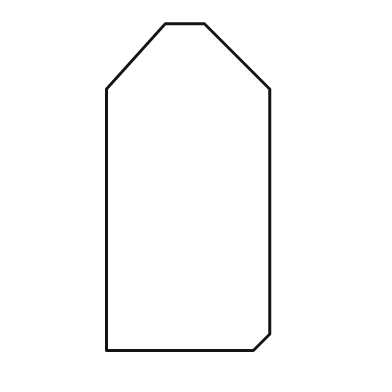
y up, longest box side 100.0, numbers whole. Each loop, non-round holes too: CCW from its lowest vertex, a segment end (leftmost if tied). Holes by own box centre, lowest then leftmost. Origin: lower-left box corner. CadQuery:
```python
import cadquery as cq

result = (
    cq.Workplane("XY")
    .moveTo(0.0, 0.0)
    .lineTo(45.0, 0.0)
    .lineTo(50.0, 5.0)
    .lineTo(50.0, 80.0)
    .lineTo(30.0, 100.0)
    .lineTo(18.0, 100.0)
    .lineTo(0.0, 80.0)
    .close()
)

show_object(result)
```